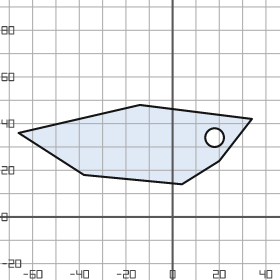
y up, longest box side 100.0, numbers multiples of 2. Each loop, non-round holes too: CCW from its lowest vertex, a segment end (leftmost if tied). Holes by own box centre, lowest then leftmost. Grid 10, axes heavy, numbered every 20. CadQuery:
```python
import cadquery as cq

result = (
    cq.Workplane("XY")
    .moveTo(4.0, 14.0)
    .lineTo(20.0, 24.0)
    .lineTo(34.0, 42.0)
    .lineTo(-14.0, 48.0)
    .lineTo(-66.0, 36.0)
    .lineTo(-38.0, 18.0)
    .close()
    .moveTo(18.0, 34.0)
    .circle(4.0)
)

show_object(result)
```